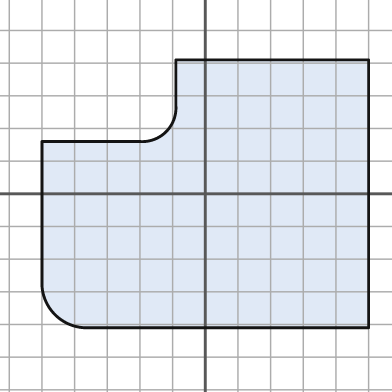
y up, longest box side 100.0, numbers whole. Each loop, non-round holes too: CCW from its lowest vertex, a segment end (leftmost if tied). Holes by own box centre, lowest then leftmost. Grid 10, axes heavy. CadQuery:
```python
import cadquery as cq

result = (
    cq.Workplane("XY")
    .moveTo(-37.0, -41.0)
    .lineTo(50.0, -41.0)
    .lineTo(50.0, 41.0)
    .lineTo(-9.0, 41.0)
    .lineTo(-9.0, 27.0)
    .threePointArc((-12.0, 19.0), (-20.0, 16.0))
    .lineTo(-50.0, 16.0)
    .lineTo(-50.0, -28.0)
    .threePointArc((-46.0, -37.0), (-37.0, -41.0))
    .close()
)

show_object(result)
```